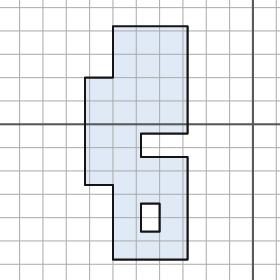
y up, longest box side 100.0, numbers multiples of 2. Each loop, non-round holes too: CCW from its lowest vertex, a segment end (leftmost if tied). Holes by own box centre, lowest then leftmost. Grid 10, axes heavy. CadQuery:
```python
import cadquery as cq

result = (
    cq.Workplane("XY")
    .moveTo(-60.0, -58.0)
    .lineTo(-28.0, -58.0)
    .lineTo(-28.0, -14.0)
    .lineTo(-48.0, -14.0)
    .lineTo(-48.0, -4.0)
    .lineTo(-28.0, -4.0)
    .lineTo(-28.0, 42.0)
    .lineTo(-60.0, 42.0)
    .lineTo(-60.0, 20.0)
    .lineTo(-72.0, 20.0)
    .lineTo(-72.0, -26.0)
    .lineTo(-60.0, -26.0)
    .close()
    .moveTo(-48.0, -46.0)
    .lineTo(-40.0, -46.0)
    .lineTo(-40.0, -34.0)
    .lineTo(-48.0, -34.0)
    .close()
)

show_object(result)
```